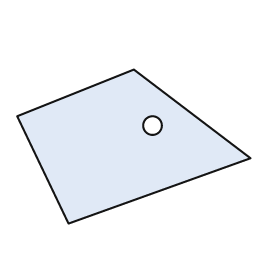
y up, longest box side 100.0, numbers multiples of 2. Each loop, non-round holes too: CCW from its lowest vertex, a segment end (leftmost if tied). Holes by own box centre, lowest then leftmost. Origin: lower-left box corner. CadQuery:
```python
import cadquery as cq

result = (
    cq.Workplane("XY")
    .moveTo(22.0, 0.0)
    .lineTo(100.0, 28.0)
    .lineTo(50.0, 66.0)
    .lineTo(0.0, 46.0)
    .close()
    .moveTo(58.0, 42.0)
    .circle(4.0)
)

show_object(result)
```